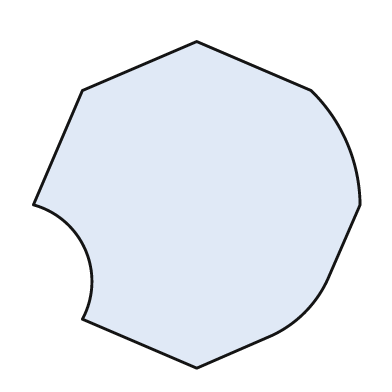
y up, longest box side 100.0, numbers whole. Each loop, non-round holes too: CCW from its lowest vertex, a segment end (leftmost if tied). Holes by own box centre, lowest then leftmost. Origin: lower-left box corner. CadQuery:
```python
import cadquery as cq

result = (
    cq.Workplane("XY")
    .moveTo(50.0, 0.0)
    .lineTo(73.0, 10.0)
    .threePointArc((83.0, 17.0), (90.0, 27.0))
    .lineTo(100.0, 50.0)
    .threePointArc((96.0, 69.0), (85.0, 85.0))
    .lineTo(50.0, 100.0)
    .lineTo(15.0, 85.0)
    .lineTo(0.0, 50.0)
    .threePointArc((16.0, 36.0), (15.0, 15.0))
    .close()
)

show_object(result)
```